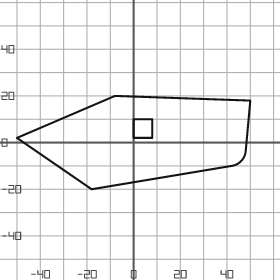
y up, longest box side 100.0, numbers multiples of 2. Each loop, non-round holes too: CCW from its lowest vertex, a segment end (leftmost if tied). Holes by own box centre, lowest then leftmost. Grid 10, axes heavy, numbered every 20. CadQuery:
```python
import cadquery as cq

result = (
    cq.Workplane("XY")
    .moveTo(-18.0, -20.0)
    .lineTo(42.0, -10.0)
    .threePointArc((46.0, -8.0), (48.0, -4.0))
    .lineTo(50.0, 18.0)
    .lineTo(-8.0, 20.0)
    .lineTo(-50.0, 2.0)
    .close()
    .moveTo(0.0, 2.0)
    .lineTo(8.0, 2.0)
    .lineTo(8.0, 10.0)
    .lineTo(0.0, 10.0)
    .close()
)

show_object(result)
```